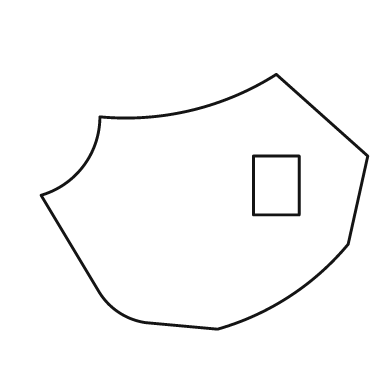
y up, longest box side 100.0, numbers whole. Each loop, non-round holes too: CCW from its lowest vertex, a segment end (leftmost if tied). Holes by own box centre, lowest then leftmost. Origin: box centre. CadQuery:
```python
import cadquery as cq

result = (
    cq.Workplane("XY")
    .moveTo(4.0, -39.0)
    .threePointArc((26.0, -29.0), (44.0, -13.0))
    .lineTo(50.0, 14.0)
    .lineTo(22.0, 39.0)
    .threePointArc((-4.0, 28.0), (-32.0, 26.0))
    .threePointArc((-37.0, 11.0), (-50.0, 2.0))
    .lineTo(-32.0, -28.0)
    .threePointArc((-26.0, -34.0), (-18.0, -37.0))
    .close()
    .moveTo(15.0, -4.0)
    .lineTo(29.0, -4.0)
    .lineTo(29.0, 14.0)
    .lineTo(15.0, 14.0)
    .close()
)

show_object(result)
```